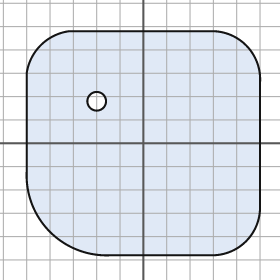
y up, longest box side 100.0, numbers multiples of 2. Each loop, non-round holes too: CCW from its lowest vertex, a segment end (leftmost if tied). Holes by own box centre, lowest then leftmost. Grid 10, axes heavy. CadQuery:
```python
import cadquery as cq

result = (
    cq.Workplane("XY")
    .moveTo(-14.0, -48.0)
    .lineTo(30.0, -48.0)
    .threePointArc((44.0, -42.0), (50.0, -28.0))
    .lineTo(50.0, 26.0)
    .threePointArc((44.0, 42.0), (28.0, 48.0))
    .lineTo(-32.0, 48.0)
    .threePointArc((-44.0, 42.0), (-50.0, 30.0))
    .lineTo(-50.0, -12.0)
    .threePointArc((-40.0, -38.0), (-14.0, -48.0))
    .close()
    .moveTo(-20.0, 18.0)
    .circle(4.0)
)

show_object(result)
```